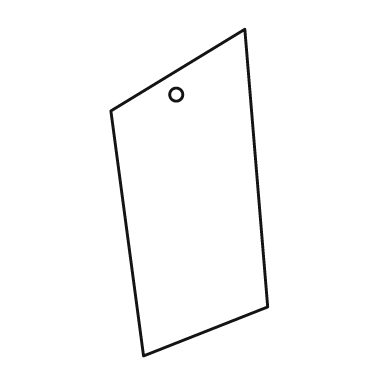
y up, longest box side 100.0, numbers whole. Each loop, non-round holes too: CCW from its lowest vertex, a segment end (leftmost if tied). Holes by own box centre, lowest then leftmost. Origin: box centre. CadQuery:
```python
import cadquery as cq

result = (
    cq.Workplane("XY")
    .moveTo(-14.0, -50.0)
    .lineTo(24.0, -35.0)
    .lineTo(17.0, 50.0)
    .lineTo(-24.0, 25.0)
    .close()
    .moveTo(-4.0, 30.0)
    .circle(2.0)
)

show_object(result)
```